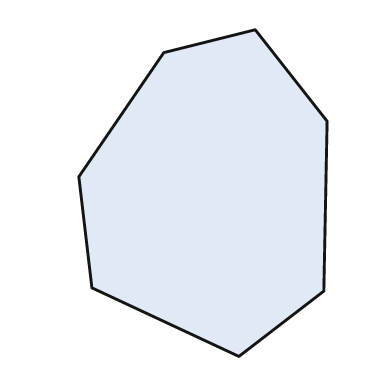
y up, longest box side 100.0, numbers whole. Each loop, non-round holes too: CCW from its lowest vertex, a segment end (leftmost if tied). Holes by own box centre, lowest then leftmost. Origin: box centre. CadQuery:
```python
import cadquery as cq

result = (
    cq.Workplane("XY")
    .moveTo(11.0, -50.0)
    .lineTo(37.0, -30.0)
    .lineTo(38.0, 22.0)
    .lineTo(16.0, 50.0)
    .lineTo(-12.0, 43.0)
    .lineTo(-38.0, 5.0)
    .lineTo(-34.0, -29.0)
    .close()
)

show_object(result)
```